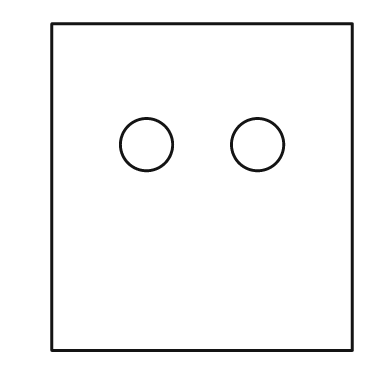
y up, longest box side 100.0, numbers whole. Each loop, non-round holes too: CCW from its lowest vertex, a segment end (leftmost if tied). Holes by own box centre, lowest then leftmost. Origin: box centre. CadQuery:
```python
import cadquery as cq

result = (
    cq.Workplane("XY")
    .moveTo(-46.0, -50.0)
    .lineTo(46.0, -50.0)
    .lineTo(46.0, 50.0)
    .lineTo(-46.0, 50.0)
    .close()
    .moveTo(-17.0, 13.0)
    .circle(8.0)
    .moveTo(17.0, 13.0)
    .circle(8.0)
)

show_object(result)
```